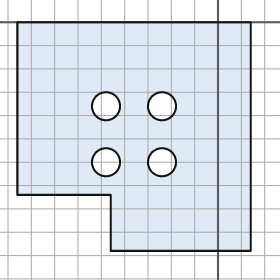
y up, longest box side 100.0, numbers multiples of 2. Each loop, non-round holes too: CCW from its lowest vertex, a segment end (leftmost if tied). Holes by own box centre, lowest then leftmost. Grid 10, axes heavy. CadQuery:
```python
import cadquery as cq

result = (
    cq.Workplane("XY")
    .moveTo(-46.0, -98.0)
    .lineTo(14.0, -98.0)
    .lineTo(14.0, 0.0)
    .lineTo(-86.0, 0.0)
    .lineTo(-86.0, -74.0)
    .lineTo(-46.0, -74.0)
    .close()
    .moveTo(-48.0, -60.0)
    .circle(6.0)
    .moveTo(-24.0, -60.0)
    .circle(6.0)
    .moveTo(-48.0, -36.0)
    .circle(6.0)
    .moveTo(-24.0, -36.0)
    .circle(6.0)
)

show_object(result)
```